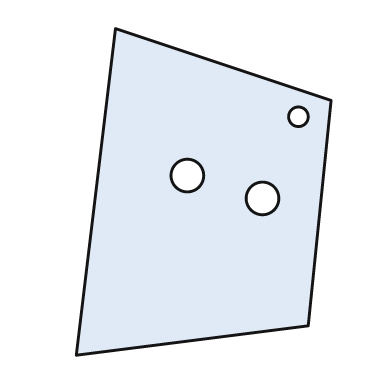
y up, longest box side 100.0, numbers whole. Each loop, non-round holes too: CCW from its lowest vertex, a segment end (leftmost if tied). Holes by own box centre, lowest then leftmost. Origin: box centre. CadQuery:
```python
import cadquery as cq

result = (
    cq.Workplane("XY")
    .moveTo(-39.0, -50.0)
    .lineTo(32.0, -41.0)
    .lineTo(39.0, 28.0)
    .lineTo(-27.0, 50.0)
    .close()
    .moveTo(18.0, -2.0)
    .circle(5.0)
    .moveTo(-5.0, 5.0)
    .circle(5.0)
    .moveTo(29.0, 23.0)
    .circle(3.0)
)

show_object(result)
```